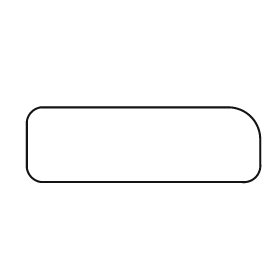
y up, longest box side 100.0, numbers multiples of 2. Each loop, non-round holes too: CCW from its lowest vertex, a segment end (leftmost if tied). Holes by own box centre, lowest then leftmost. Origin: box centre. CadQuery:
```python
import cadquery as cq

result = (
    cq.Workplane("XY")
    .moveTo(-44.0, -16.0)
    .lineTo(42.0, -16.0)
    .threePointArc((48.0, -14.0), (50.0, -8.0))
    .lineTo(50.0, 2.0)
    .threePointArc((46.0, 12.0), (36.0, 16.0))
    .lineTo(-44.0, 16.0)
    .threePointArc((-48.0, 14.0), (-50.0, 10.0))
    .lineTo(-50.0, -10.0)
    .threePointArc((-48.0, -14.0), (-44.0, -16.0))
    .close()
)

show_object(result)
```